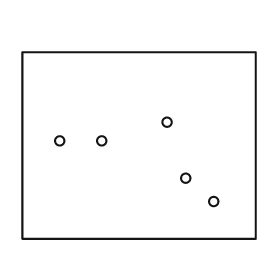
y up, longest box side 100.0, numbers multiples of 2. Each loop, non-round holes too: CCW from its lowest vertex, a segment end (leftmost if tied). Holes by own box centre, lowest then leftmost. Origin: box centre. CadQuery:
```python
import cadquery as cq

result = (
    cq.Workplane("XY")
    .moveTo(-50.0, -40.0)
    .lineTo(50.0, -40.0)
    .lineTo(50.0, 40.0)
    .lineTo(-50.0, 40.0)
    .close()
    .moveTo(32.0, -24.0)
    .circle(2.0)
    .moveTo(20.0, -14.0)
    .circle(2.0)
    .moveTo(-34.0, 2.0)
    .circle(2.0)
    .moveTo(-16.0, 2.0)
    .circle(2.0)
    .moveTo(12.0, 10.0)
    .circle(2.0)
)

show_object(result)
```